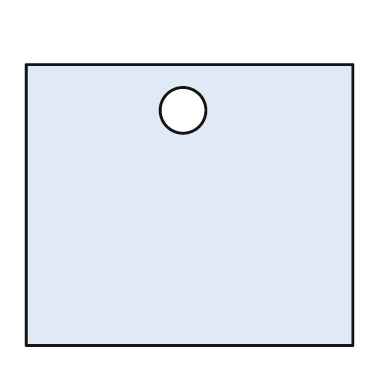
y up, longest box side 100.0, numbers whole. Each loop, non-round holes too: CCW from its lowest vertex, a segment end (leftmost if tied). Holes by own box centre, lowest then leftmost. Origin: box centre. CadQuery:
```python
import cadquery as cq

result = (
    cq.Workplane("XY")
    .moveTo(-50.0, -43.0)
    .lineTo(50.0, -43.0)
    .lineTo(50.0, 43.0)
    .lineTo(-50.0, 43.0)
    .close()
    .moveTo(-2.0, 29.0)
    .circle(7.0)
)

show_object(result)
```